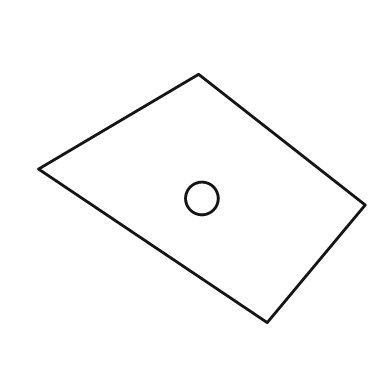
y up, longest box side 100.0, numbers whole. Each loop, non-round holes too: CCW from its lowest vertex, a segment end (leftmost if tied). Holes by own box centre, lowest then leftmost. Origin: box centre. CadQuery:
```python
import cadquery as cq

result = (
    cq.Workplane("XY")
    .moveTo(20.0, -38.0)
    .lineTo(50.0, -2.0)
    .lineTo(-1.0, 38.0)
    .lineTo(-50.0, 9.0)
    .close()
    .moveTo(0.0, 0.0)
    .circle(5.0)
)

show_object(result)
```